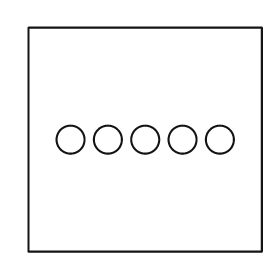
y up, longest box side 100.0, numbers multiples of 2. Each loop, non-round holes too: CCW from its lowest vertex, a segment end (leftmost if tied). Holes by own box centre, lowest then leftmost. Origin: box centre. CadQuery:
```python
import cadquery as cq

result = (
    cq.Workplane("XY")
    .moveTo(-50.0, -48.0)
    .lineTo(50.0, -48.0)
    .lineTo(50.0, 48.0)
    .lineTo(-50.0, 48.0)
    .close()
    .moveTo(-32.0, 0.0)
    .circle(6.0)
    .moveTo(-16.0, 0.0)
    .circle(6.0)
    .moveTo(0.0, 0.0)
    .circle(6.0)
    .moveTo(16.0, 0.0)
    .circle(6.0)
    .moveTo(32.0, 0.0)
    .circle(6.0)
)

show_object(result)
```